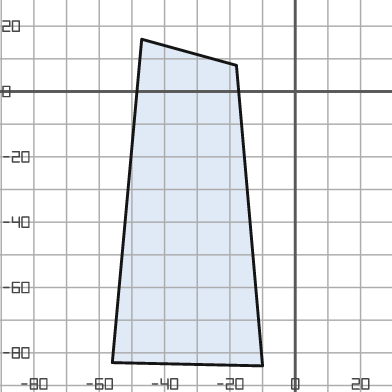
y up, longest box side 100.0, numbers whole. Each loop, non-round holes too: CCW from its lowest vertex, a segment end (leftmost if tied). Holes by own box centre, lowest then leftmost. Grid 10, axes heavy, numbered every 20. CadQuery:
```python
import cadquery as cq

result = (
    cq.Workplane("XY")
    .moveTo(-10.0, -84.0)
    .lineTo(-18.0, 8.0)
    .lineTo(-47.0, 16.0)
    .lineTo(-56.0, -83.0)
    .close()
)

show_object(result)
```